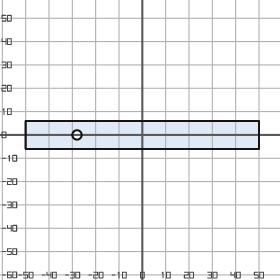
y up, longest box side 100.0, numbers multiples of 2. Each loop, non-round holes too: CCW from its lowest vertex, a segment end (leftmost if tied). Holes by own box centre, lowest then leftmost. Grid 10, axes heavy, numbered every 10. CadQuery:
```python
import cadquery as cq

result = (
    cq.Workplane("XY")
    .moveTo(-50.0, -6.0)
    .lineTo(50.0, -6.0)
    .lineTo(50.0, 6.0)
    .lineTo(-50.0, 6.0)
    .close()
    .moveTo(-28.0, 0.0)
    .circle(2.0)
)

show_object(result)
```